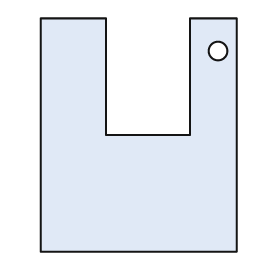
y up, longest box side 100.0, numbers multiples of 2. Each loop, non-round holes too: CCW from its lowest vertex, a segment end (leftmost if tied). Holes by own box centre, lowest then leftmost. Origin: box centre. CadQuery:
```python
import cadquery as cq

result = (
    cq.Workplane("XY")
    .moveTo(-42.0, -50.0)
    .lineTo(42.0, -50.0)
    .lineTo(42.0, 50.0)
    .lineTo(22.0, 50.0)
    .lineTo(22.0, 0.0)
    .lineTo(-14.0, 0.0)
    .lineTo(-14.0, 50.0)
    .lineTo(-42.0, 50.0)
    .close()
    .moveTo(34.0, 36.0)
    .circle(4.0)
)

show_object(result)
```